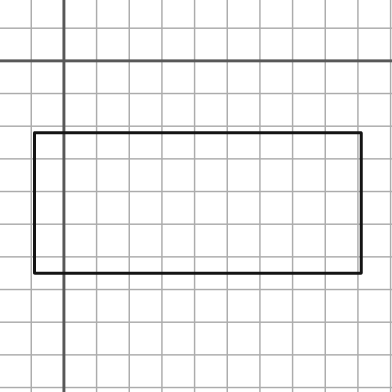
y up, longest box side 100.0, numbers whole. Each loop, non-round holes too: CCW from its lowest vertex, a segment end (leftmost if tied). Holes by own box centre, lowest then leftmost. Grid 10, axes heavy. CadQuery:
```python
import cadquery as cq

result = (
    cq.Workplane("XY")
    .moveTo(-9.0, -65.0)
    .lineTo(91.0, -65.0)
    .lineTo(91.0, -22.0)
    .lineTo(-9.0, -22.0)
    .close()
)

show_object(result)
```